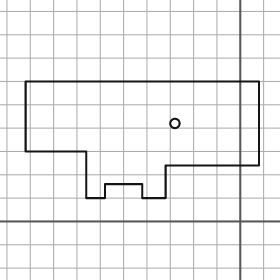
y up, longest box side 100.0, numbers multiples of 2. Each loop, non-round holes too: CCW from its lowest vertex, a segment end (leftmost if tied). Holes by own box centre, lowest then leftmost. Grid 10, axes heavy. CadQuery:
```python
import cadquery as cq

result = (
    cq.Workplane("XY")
    .moveTo(-66.0, 10.0)
    .lineTo(-58.0, 10.0)
    .lineTo(-58.0, 16.0)
    .lineTo(-42.0, 16.0)
    .lineTo(-42.0, 10.0)
    .lineTo(-32.0, 10.0)
    .lineTo(-32.0, 24.0)
    .lineTo(8.0, 24.0)
    .lineTo(8.0, 60.0)
    .lineTo(-92.0, 60.0)
    .lineTo(-92.0, 30.0)
    .lineTo(-66.0, 30.0)
    .close()
    .moveTo(-28.0, 42.0)
    .circle(2.0)
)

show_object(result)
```